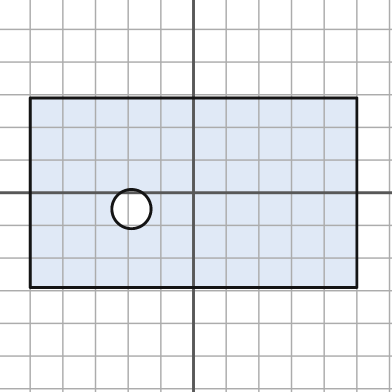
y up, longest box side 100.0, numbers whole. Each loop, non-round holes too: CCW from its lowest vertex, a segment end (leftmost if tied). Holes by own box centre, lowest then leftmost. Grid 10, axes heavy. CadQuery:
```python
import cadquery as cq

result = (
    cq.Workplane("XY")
    .moveTo(-50.0, -29.0)
    .lineTo(50.0, -29.0)
    .lineTo(50.0, 29.0)
    .lineTo(-50.0, 29.0)
    .close()
    .moveTo(-19.0, -5.0)
    .circle(6.0)
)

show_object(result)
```